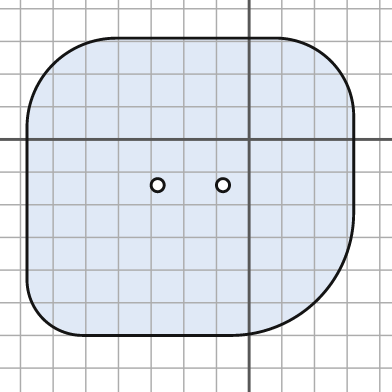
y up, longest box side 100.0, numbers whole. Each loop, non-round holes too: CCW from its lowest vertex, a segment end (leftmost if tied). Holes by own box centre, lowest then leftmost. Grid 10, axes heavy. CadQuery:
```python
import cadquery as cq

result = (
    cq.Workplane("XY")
    .moveTo(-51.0, -60.0)
    .lineTo(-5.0, -60.0)
    .threePointArc((21.0, -49.0), (32.0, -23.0))
    .lineTo(32.0, 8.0)
    .threePointArc((25.0, 24.0), (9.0, 31.0))
    .lineTo(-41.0, 31.0)
    .threePointArc((-60.0, 23.0), (-68.0, 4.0))
    .lineTo(-68.0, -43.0)
    .threePointArc((-63.0, -55.0), (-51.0, -60.0))
    .close()
    .moveTo(-28.0, -14.0)
    .circle(2.0)
    .moveTo(-8.0, -14.0)
    .circle(2.0)
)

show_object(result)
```